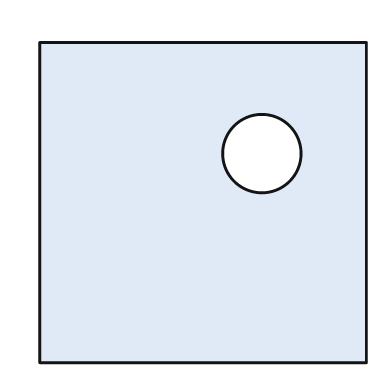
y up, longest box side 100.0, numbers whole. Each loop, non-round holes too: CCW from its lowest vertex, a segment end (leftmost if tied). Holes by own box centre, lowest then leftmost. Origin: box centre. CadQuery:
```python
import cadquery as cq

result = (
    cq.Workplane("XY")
    .moveTo(-50.0, -49.0)
    .lineTo(50.0, -49.0)
    .lineTo(50.0, 49.0)
    .lineTo(-50.0, 49.0)
    .close()
    .moveTo(18.0, 15.0)
    .circle(12.0)
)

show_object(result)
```